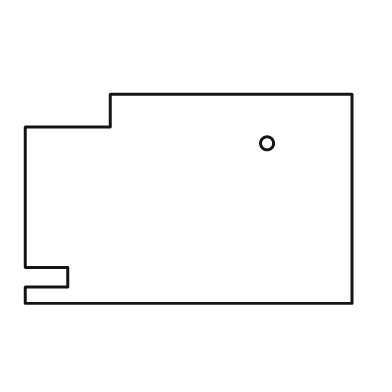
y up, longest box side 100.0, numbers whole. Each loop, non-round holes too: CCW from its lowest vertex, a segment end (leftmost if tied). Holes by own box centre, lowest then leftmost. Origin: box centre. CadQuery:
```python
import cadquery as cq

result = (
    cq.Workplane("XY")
    .moveTo(-50.0, -32.0)
    .lineTo(50.0, -32.0)
    .lineTo(50.0, 32.0)
    .lineTo(-24.0, 32.0)
    .lineTo(-24.0, 22.0)
    .lineTo(-50.0, 22.0)
    .lineTo(-50.0, -21.0)
    .lineTo(-37.0, -21.0)
    .lineTo(-37.0, -27.0)
    .lineTo(-50.0, -27.0)
    .close()
    .moveTo(24.0, 17.0)
    .circle(2.0)
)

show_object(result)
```